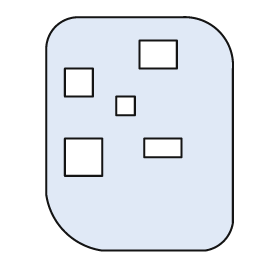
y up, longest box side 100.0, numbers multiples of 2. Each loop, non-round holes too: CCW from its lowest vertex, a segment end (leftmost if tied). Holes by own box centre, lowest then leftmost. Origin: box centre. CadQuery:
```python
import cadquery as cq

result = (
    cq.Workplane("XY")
    .moveTo(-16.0, -50.0)
    .lineTo(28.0, -50.0)
    .threePointArc((36.0, -46.0), (40.0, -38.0))
    .lineTo(40.0, 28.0)
    .threePointArc((34.0, 44.0), (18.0, 50.0))
    .lineTo(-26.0, 50.0)
    .threePointArc((-36.0, 46.0), (-40.0, 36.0))
    .lineTo(-40.0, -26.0)
    .threePointArc((-32.0, -42.0), (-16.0, -50.0))
    .close()
    .moveTo(-32.0, -18.0)
    .lineTo(-16.0, -18.0)
    .lineTo(-16.0, -2.0)
    .lineTo(-32.0, -2.0)
    .close()
    .moveTo(2.0, -10.0)
    .lineTo(18.0, -10.0)
    .lineTo(18.0, -2.0)
    .lineTo(2.0, -2.0)
    .close()
    .moveTo(-10.0, 8.0)
    .lineTo(-2.0, 8.0)
    .lineTo(-2.0, 16.0)
    .lineTo(-10.0, 16.0)
    .close()
    .moveTo(-32.0, 16.0)
    .lineTo(-20.0, 16.0)
    .lineTo(-20.0, 28.0)
    .lineTo(-32.0, 28.0)
    .close()
    .moveTo(0.0, 28.0)
    .lineTo(16.0, 28.0)
    .lineTo(16.0, 40.0)
    .lineTo(0.0, 40.0)
    .close()
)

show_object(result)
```